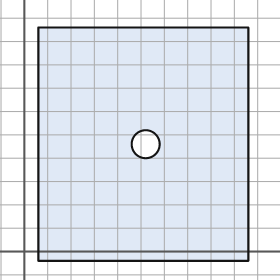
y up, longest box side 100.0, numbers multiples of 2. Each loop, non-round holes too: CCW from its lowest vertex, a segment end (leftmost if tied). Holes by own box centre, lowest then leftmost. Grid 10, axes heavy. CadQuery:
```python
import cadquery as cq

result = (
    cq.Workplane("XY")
    .moveTo(6.0, -4.0)
    .lineTo(96.0, -4.0)
    .lineTo(96.0, 96.0)
    .lineTo(6.0, 96.0)
    .close()
    .moveTo(52.0, 46.0)
    .circle(6.0)
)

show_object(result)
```